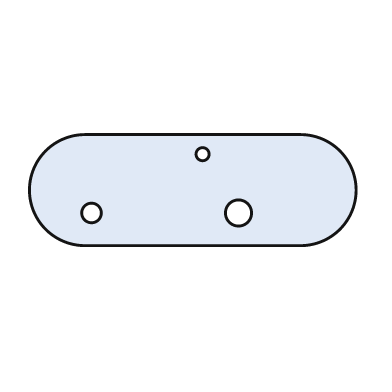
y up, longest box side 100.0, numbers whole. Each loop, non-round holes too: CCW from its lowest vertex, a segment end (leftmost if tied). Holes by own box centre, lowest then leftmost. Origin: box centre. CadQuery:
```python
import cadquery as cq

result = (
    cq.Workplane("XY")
    .moveTo(-33.0, -17.0)
    .lineTo(33.0, -17.0)
    .threePointArc((50.0, 0.0), (33.0, 17.0))
    .lineTo(-33.0, 17.0)
    .threePointArc((-50.0, 0.0), (-33.0, -17.0))
    .close()
    .moveTo(-31.0, -7.0)
    .circle(3.0)
    .moveTo(14.0, -7.0)
    .circle(4.0)
    .moveTo(3.0, 11.0)
    .circle(2.0)
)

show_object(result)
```